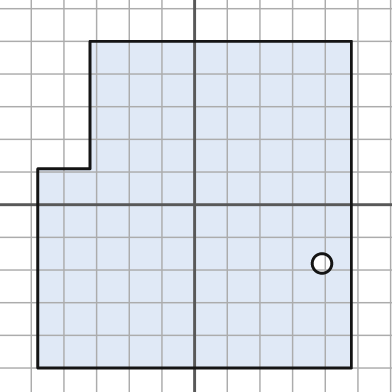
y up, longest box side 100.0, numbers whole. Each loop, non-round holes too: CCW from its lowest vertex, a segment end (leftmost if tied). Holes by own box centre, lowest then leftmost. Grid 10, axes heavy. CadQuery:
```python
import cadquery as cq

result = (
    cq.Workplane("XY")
    .moveTo(-48.0, -50.0)
    .lineTo(48.0, -50.0)
    .lineTo(48.0, 50.0)
    .lineTo(-32.0, 50.0)
    .lineTo(-32.0, 11.0)
    .lineTo(-48.0, 11.0)
    .close()
    .moveTo(39.0, -18.0)
    .circle(3.0)
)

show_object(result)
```